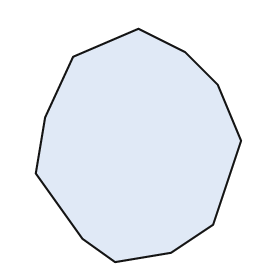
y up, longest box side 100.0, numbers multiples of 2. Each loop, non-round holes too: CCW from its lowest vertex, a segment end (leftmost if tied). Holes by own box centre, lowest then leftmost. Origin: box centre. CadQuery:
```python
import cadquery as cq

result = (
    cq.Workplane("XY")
    .moveTo(-10.0, -50.0)
    .lineTo(14.0, -46.0)
    .lineTo(32.0, -34.0)
    .lineTo(44.0, 2.0)
    .lineTo(34.0, 26.0)
    .lineTo(20.0, 40.0)
    .lineTo(0.0, 50.0)
    .lineTo(-28.0, 38.0)
    .lineTo(-40.0, 12.0)
    .lineTo(-44.0, -12.0)
    .lineTo(-24.0, -40.0)
    .close()
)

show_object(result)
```